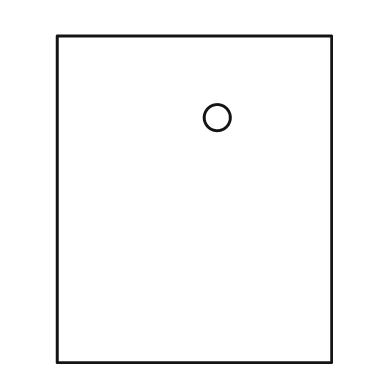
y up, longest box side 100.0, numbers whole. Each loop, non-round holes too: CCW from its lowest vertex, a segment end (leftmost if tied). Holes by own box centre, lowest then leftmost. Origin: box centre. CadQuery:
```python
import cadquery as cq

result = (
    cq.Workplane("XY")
    .moveTo(-42.0, -50.0)
    .lineTo(42.0, -50.0)
    .lineTo(42.0, 50.0)
    .lineTo(-42.0, 50.0)
    .close()
    .moveTo(7.0, 25.0)
    .circle(4.0)
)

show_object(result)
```